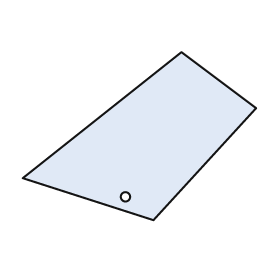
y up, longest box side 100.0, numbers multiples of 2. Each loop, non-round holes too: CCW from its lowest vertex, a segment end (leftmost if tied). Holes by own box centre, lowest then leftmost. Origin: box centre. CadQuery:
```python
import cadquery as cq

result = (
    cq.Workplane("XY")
    .moveTo(6.0, -36.0)
    .lineTo(50.0, 12.0)
    .lineTo(18.0, 36.0)
    .lineTo(-50.0, -18.0)
    .close()
    .moveTo(-6.0, -26.0)
    .circle(2.0)
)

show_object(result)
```